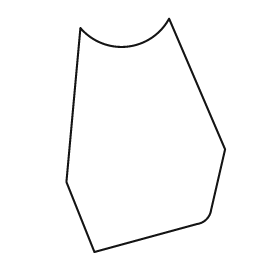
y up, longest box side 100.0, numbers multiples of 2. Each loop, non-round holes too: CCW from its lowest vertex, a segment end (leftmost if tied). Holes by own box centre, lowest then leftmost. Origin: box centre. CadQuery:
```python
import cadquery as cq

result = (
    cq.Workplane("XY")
    .moveTo(-22.0, -50.0)
    .lineTo(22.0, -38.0)
    .threePointArc((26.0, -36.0), (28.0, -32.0))
    .lineTo(34.0, -6.0)
    .lineTo(10.0, 50.0)
    .threePointArc((-8.0, 38.0), (-28.0, 46.0))
    .lineTo(-34.0, -20.0)
    .close()
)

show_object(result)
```